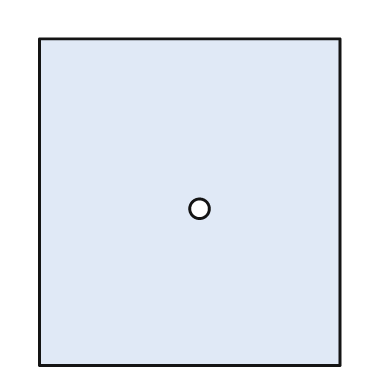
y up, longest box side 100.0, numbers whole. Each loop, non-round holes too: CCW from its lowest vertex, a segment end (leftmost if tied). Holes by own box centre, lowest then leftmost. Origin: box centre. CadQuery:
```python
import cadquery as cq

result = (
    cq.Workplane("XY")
    .moveTo(-46.0, -50.0)
    .lineTo(46.0, -50.0)
    .lineTo(46.0, 50.0)
    .lineTo(-46.0, 50.0)
    .close()
    .moveTo(3.0, -2.0)
    .circle(3.0)
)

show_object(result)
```